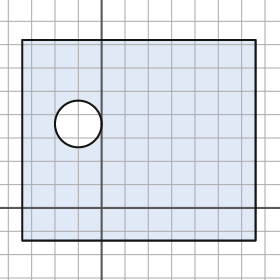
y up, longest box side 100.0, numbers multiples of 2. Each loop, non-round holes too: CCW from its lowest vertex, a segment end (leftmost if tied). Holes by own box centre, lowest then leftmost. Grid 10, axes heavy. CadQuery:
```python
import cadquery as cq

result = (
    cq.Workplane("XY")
    .moveTo(-34.0, -14.0)
    .lineTo(66.0, -14.0)
    .lineTo(66.0, 72.0)
    .lineTo(-34.0, 72.0)
    .close()
    .moveTo(-10.0, 36.0)
    .circle(10.0)
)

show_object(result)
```